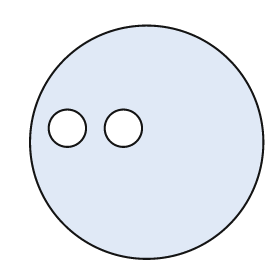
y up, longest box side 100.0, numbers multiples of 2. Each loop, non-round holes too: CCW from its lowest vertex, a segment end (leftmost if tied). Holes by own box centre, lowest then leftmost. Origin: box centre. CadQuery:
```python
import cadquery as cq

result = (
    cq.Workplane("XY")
    .moveTo(0.0, 0.0)
    .circle(50.0)
    .moveTo(-34.0, 6.0)
    .circle(8.0)
    .moveTo(-10.0, 6.0)
    .circle(8.0)
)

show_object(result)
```